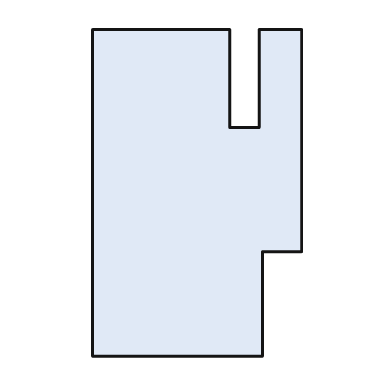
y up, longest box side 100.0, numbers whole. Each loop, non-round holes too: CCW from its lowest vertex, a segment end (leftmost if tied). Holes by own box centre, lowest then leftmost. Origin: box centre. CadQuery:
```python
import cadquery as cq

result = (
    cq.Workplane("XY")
    .moveTo(-32.0, -50.0)
    .lineTo(20.0, -50.0)
    .lineTo(20.0, -18.0)
    .lineTo(32.0, -18.0)
    .lineTo(32.0, 50.0)
    .lineTo(19.0, 50.0)
    .lineTo(19.0, 20.0)
    .lineTo(10.0, 20.0)
    .lineTo(10.0, 50.0)
    .lineTo(-32.0, 50.0)
    .close()
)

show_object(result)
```